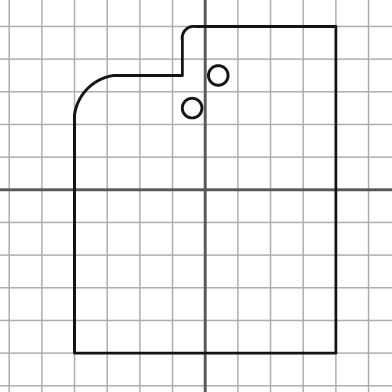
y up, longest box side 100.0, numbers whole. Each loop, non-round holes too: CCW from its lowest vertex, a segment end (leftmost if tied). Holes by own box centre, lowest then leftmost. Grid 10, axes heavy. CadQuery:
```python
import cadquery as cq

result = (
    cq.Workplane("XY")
    .moveTo(-40.0, -50.0)
    .lineTo(40.0, -50.0)
    .lineTo(40.0, 50.0)
    .lineTo(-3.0, 50.0)
    .threePointArc((-6.0, 49.0), (-7.0, 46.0))
    .lineTo(-7.0, 35.0)
    .lineTo(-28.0, 35.0)
    .threePointArc((-36.0, 31.0), (-40.0, 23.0))
    .close()
    .moveTo(-4.0, 25.0)
    .circle(3.0)
    .moveTo(4.0, 35.0)
    .circle(3.0)
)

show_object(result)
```